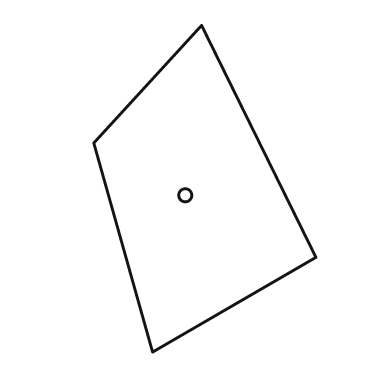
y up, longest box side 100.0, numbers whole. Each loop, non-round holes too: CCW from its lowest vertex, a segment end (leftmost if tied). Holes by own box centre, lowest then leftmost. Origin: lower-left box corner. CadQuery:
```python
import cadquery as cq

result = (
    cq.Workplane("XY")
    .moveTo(18.0, 0.0)
    .lineTo(68.0, 29.0)
    .lineTo(33.0, 100.0)
    .lineTo(0.0, 64.0)
    .close()
    .moveTo(28.0, 48.0)
    .circle(2.0)
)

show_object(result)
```